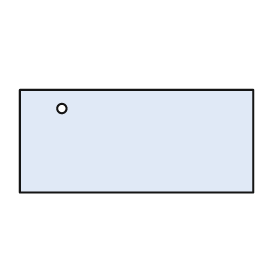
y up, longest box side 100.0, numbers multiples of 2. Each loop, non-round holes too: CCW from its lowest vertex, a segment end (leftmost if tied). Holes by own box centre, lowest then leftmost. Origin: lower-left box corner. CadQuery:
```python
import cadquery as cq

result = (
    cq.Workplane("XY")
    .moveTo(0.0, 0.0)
    .lineTo(100.0, 0.0)
    .lineTo(100.0, 44.0)
    .lineTo(0.0, 44.0)
    .close()
    .moveTo(18.0, 36.0)
    .circle(2.0)
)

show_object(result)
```